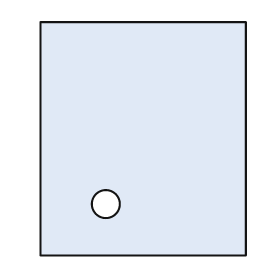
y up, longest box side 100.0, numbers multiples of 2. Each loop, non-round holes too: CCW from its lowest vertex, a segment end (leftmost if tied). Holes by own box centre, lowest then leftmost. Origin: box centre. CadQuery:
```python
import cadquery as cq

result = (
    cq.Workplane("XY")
    .moveTo(-44.0, -50.0)
    .lineTo(44.0, -50.0)
    .lineTo(44.0, 50.0)
    .lineTo(-44.0, 50.0)
    .close()
    .moveTo(-16.0, -28.0)
    .circle(6.0)
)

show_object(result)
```